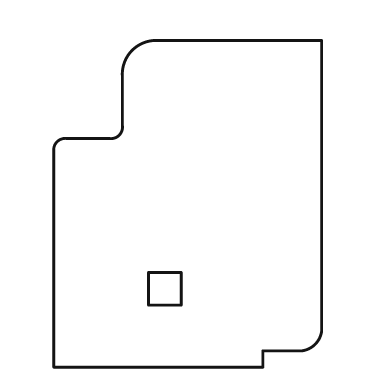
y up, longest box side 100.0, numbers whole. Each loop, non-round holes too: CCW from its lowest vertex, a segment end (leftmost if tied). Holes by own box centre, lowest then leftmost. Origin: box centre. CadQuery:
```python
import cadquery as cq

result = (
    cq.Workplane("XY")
    .moveTo(-41.0, -50.0)
    .lineTo(23.0, -50.0)
    .lineTo(23.0, -45.0)
    .lineTo(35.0, -45.0)
    .threePointArc((39.0, -43.0), (41.0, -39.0))
    .lineTo(41.0, 50.0)
    .lineTo(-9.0, 50.0)
    .threePointArc((-17.0, 47.0), (-20.0, 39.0))
    .lineTo(-20.0, 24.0)
    .threePointArc((-21.0, 21.0), (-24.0, 20.0))
    .lineTo(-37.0, 20.0)
    .threePointArc((-40.0, 19.0), (-41.0, 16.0))
    .close()
    .moveTo(-12.0, -31.0)
    .lineTo(-2.0, -31.0)
    .lineTo(-2.0, -21.0)
    .lineTo(-12.0, -21.0)
    .close()
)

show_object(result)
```